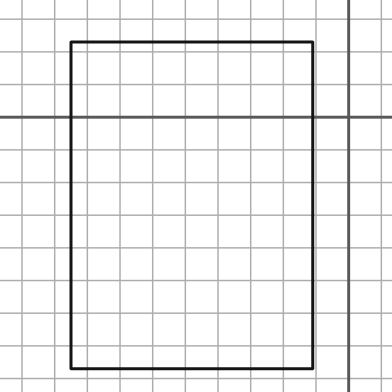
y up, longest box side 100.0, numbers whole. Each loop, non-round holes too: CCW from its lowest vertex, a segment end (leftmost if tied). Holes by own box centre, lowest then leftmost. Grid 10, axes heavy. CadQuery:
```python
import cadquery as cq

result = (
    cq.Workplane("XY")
    .moveTo(-85.0, -77.0)
    .lineTo(-11.0, -77.0)
    .lineTo(-11.0, 23.0)
    .lineTo(-85.0, 23.0)
    .close()
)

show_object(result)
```